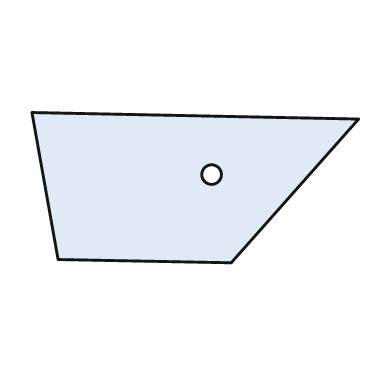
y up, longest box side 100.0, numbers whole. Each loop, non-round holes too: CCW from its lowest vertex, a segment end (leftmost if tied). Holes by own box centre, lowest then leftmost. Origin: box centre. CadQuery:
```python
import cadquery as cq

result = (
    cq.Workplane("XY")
    .moveTo(11.0, -23.0)
    .lineTo(50.0, 21.0)
    .lineTo(-50.0, 23.0)
    .lineTo(-42.0, -22.0)
    .close()
    .moveTo(5.0, 4.0)
    .circle(3.0)
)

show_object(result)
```